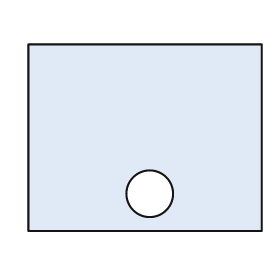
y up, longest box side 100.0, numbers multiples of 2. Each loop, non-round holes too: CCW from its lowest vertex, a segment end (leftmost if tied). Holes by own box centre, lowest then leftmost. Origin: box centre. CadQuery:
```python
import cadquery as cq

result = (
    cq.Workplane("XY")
    .moveTo(-50.0, -40.0)
    .lineTo(50.0, -40.0)
    .lineTo(50.0, 40.0)
    .lineTo(-50.0, 40.0)
    .close()
    .moveTo(2.0, -24.0)
    .circle(10.0)
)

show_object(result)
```